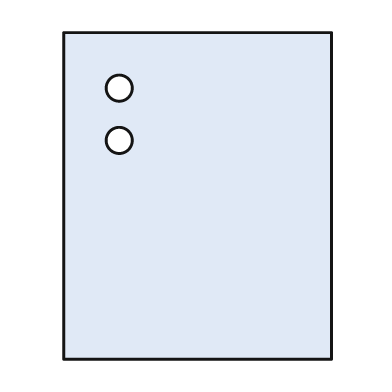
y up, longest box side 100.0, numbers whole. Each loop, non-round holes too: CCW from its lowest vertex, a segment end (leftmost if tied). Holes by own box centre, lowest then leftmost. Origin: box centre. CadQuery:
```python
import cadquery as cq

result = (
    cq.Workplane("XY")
    .moveTo(-41.0, -50.0)
    .lineTo(41.0, -50.0)
    .lineTo(41.0, 50.0)
    .lineTo(-41.0, 50.0)
    .close()
    .moveTo(-24.0, 17.0)
    .circle(4.0)
    .moveTo(-24.0, 33.0)
    .circle(4.0)
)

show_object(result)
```